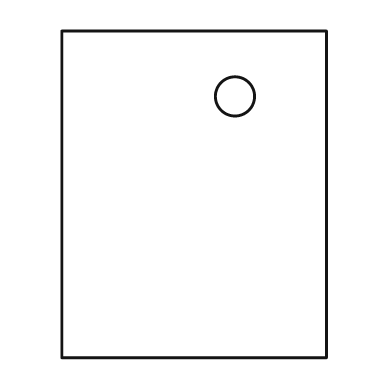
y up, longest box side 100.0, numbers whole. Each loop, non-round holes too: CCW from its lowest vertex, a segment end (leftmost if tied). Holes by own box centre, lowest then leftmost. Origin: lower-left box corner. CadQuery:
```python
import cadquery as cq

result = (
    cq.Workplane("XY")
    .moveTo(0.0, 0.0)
    .lineTo(81.0, 0.0)
    .lineTo(81.0, 100.0)
    .lineTo(0.0, 100.0)
    .close()
    .moveTo(53.0, 80.0)
    .circle(6.0)
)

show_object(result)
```